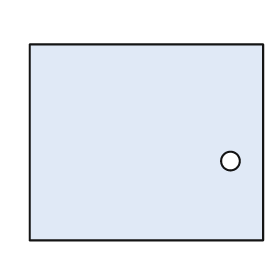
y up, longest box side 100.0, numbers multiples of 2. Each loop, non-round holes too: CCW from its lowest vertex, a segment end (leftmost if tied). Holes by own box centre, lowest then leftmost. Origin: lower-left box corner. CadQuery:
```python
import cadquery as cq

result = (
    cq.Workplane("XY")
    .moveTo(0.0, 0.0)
    .lineTo(100.0, 0.0)
    .lineTo(100.0, 84.0)
    .lineTo(0.0, 84.0)
    .close()
    .moveTo(86.0, 34.0)
    .circle(4.0)
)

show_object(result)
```